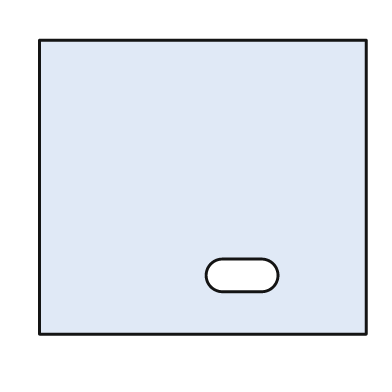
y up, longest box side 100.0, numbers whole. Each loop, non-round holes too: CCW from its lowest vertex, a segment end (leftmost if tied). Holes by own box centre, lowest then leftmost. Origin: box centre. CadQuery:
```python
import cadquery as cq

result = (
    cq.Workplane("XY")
    .moveTo(-50.0, -45.0)
    .lineTo(50.0, -45.0)
    .lineTo(50.0, 45.0)
    .lineTo(-50.0, 45.0)
    .close()
    .moveTo(6.0, -32.0)
    .lineTo(18.0, -32.0)
    .threePointArc((23.0, -27.0), (18.0, -22.0))
    .lineTo(6.0, -22.0)
    .threePointArc((1.0, -27.0), (6.0, -32.0))
    .close()
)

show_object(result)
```